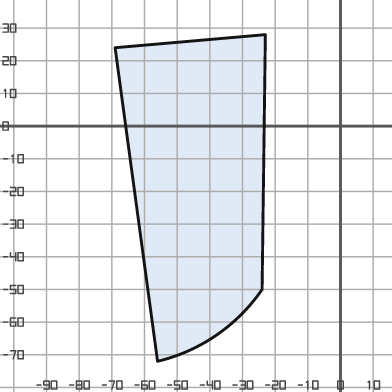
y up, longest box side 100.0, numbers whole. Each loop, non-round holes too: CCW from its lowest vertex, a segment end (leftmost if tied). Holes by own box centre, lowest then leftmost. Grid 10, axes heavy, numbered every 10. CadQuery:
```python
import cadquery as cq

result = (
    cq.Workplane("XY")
    .moveTo(-56.0, -72.0)
    .threePointArc((-38.0, -64.0), (-24.0, -50.0))
    .lineTo(-23.0, 28.0)
    .lineTo(-69.0, 24.0)
    .close()
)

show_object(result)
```